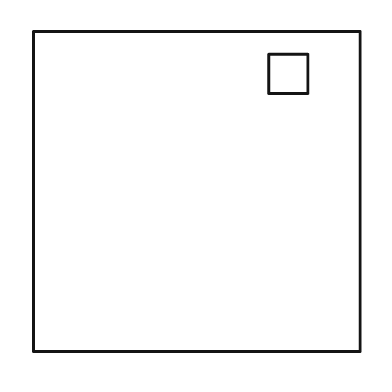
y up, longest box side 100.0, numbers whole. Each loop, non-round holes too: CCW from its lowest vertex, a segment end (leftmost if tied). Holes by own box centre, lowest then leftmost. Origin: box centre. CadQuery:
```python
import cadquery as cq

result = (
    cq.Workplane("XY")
    .moveTo(-50.0, -49.0)
    .lineTo(50.0, -49.0)
    .lineTo(50.0, 49.0)
    .lineTo(-50.0, 49.0)
    .close()
    .moveTo(22.0, 30.0)
    .lineTo(34.0, 30.0)
    .lineTo(34.0, 42.0)
    .lineTo(22.0, 42.0)
    .close()
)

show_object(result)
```